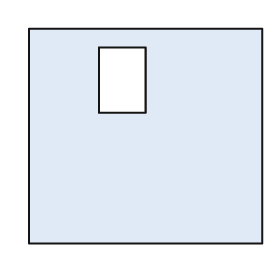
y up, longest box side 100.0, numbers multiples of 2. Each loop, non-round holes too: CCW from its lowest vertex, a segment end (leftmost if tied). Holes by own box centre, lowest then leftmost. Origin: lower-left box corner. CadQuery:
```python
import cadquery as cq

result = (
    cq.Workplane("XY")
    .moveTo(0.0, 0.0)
    .lineTo(100.0, 0.0)
    .lineTo(100.0, 92.0)
    .lineTo(0.0, 92.0)
    .close()
    .moveTo(30.0, 56.0)
    .lineTo(50.0, 56.0)
    .lineTo(50.0, 84.0)
    .lineTo(30.0, 84.0)
    .close()
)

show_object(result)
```